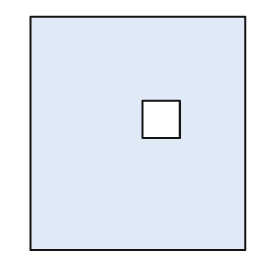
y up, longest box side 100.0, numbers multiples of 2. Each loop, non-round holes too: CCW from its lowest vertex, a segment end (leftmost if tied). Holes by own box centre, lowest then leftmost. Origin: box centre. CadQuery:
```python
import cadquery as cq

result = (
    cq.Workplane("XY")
    .moveTo(-46.0, -50.0)
    .lineTo(46.0, -50.0)
    .lineTo(46.0, 50.0)
    .lineTo(-46.0, 50.0)
    .close()
    .moveTo(2.0, -2.0)
    .lineTo(18.0, -2.0)
    .lineTo(18.0, 14.0)
    .lineTo(2.0, 14.0)
    .close()
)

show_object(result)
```